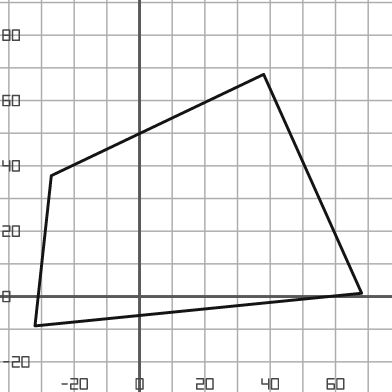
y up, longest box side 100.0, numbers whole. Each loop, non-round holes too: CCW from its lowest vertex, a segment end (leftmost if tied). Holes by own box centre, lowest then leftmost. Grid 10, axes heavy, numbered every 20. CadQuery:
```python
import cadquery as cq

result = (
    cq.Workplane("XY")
    .moveTo(-32.0, -9.0)
    .lineTo(68.0, 1.0)
    .lineTo(38.0, 68.0)
    .lineTo(-27.0, 37.0)
    .close()
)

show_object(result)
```